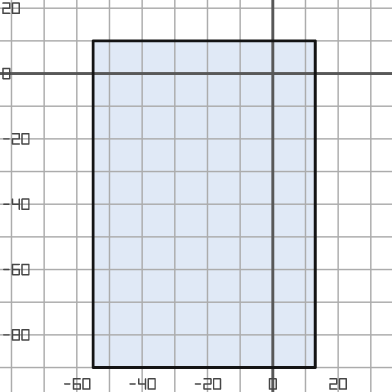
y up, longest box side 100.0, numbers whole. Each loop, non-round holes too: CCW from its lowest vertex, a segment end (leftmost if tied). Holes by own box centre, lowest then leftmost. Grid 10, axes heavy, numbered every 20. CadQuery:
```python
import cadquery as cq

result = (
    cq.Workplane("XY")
    .moveTo(-55.0, -90.0)
    .lineTo(13.0, -90.0)
    .lineTo(13.0, 10.0)
    .lineTo(-55.0, 10.0)
    .close()
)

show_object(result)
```